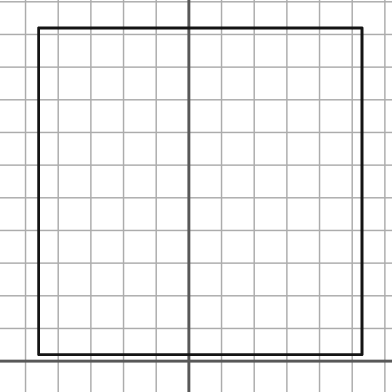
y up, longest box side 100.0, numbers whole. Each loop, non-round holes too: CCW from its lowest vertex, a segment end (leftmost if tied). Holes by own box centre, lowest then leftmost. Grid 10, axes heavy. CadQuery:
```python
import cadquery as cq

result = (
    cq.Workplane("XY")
    .moveTo(-46.0, 2.0)
    .lineTo(53.0, 2.0)
    .lineTo(53.0, 102.0)
    .lineTo(-46.0, 102.0)
    .close()
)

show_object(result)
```